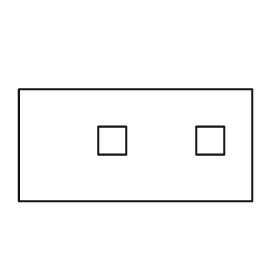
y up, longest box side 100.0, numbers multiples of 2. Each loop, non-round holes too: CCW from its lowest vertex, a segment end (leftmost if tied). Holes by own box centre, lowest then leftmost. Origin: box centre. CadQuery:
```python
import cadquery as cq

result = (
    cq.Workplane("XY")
    .moveTo(-50.0, -24.0)
    .lineTo(50.0, -24.0)
    .lineTo(50.0, 24.0)
    .lineTo(-50.0, 24.0)
    .close()
    .moveTo(-16.0, -4.0)
    .lineTo(-4.0, -4.0)
    .lineTo(-4.0, 8.0)
    .lineTo(-16.0, 8.0)
    .close()
    .moveTo(26.0, -4.0)
    .lineTo(38.0, -4.0)
    .lineTo(38.0, 8.0)
    .lineTo(26.0, 8.0)
    .close()
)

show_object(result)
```